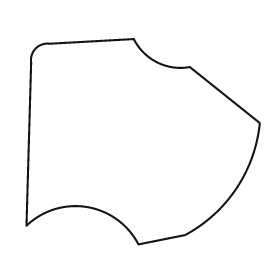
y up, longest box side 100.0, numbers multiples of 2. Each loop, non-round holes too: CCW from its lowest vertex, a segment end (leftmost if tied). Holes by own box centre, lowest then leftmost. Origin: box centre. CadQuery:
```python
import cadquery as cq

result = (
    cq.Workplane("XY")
    .moveTo(-2.0, -44.0)
    .lineTo(18.0, -40.0)
    .threePointArc((40.0, -20.0), (50.0, 8.0))
    .lineTo(20.0, 32.0)
    .threePointArc((6.0, 34.0), (-4.0, 44.0))
    .lineTo(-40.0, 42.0)
    .threePointArc((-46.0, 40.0), (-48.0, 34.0))
    .lineTo(-50.0, -36.0)
    .threePointArc((-24.0, -28.0), (-2.0, -44.0))
    .close()
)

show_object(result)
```